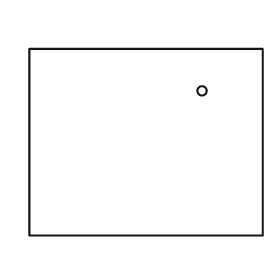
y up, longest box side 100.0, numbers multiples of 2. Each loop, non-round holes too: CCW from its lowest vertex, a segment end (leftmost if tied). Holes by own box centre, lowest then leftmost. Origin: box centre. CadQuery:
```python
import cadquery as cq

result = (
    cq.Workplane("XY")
    .moveTo(-50.0, -40.0)
    .lineTo(50.0, -40.0)
    .lineTo(50.0, 40.0)
    .lineTo(-50.0, 40.0)
    .close()
    .moveTo(24.0, 22.0)
    .circle(2.0)
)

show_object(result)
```